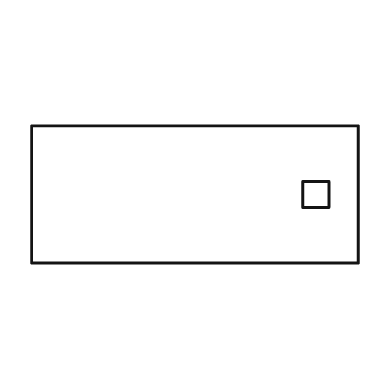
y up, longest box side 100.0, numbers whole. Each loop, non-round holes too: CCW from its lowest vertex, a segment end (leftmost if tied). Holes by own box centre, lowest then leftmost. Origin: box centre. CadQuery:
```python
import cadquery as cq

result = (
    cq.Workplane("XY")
    .moveTo(-50.0, -21.0)
    .lineTo(50.0, -21.0)
    .lineTo(50.0, 21.0)
    .lineTo(-50.0, 21.0)
    .close()
    .moveTo(33.0, -4.0)
    .lineTo(41.0, -4.0)
    .lineTo(41.0, 4.0)
    .lineTo(33.0, 4.0)
    .close()
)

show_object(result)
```